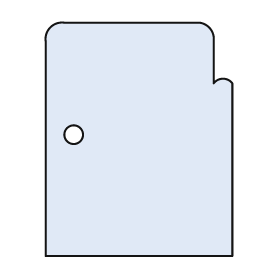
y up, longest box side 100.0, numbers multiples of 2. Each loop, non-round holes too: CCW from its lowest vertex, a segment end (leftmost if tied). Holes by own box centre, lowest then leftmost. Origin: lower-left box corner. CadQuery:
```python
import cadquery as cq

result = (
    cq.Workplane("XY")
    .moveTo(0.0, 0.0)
    .lineTo(80.0, 0.0)
    .lineTo(80.0, 74.0)
    .threePointArc((76.0, 76.0), (72.0, 74.0))
    .lineTo(72.0, 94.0)
    .threePointArc((70.0, 98.0), (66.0, 100.0))
    .lineTo(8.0, 100.0)
    .threePointArc((2.0, 98.0), (0.0, 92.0))
    .close()
    .moveTo(12.0, 52.0)
    .circle(4.0)
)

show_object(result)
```